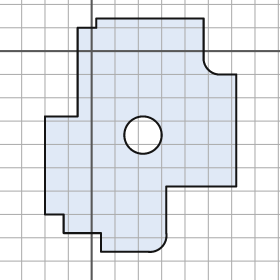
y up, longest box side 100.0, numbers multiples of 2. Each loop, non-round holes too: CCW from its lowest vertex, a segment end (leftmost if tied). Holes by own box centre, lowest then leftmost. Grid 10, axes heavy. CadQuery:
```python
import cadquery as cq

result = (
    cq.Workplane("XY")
    .moveTo(4.0, -86.0)
    .lineTo(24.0, -86.0)
    .threePointArc((30.0, -84.0), (32.0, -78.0))
    .lineTo(32.0, -58.0)
    .lineTo(62.0, -58.0)
    .lineTo(62.0, -10.0)
    .lineTo(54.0, -10.0)
    .threePointArc((50.0, -8.0), (48.0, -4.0))
    .lineTo(48.0, 14.0)
    .lineTo(2.0, 14.0)
    .lineTo(2.0, 10.0)
    .lineTo(-6.0, 10.0)
    .lineTo(-6.0, -28.0)
    .lineTo(-20.0, -28.0)
    .lineTo(-20.0, -70.0)
    .lineTo(-12.0, -70.0)
    .lineTo(-12.0, -78.0)
    .lineTo(4.0, -78.0)
    .close()
    .moveTo(22.0, -36.0)
    .circle(8.0)
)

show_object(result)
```